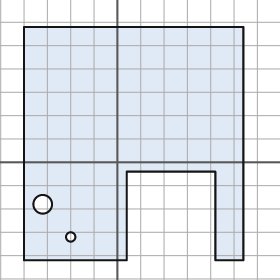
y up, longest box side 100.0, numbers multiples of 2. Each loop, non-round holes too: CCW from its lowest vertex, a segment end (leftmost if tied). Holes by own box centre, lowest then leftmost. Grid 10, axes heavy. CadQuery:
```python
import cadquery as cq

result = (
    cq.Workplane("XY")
    .moveTo(-40.0, -42.0)
    .lineTo(4.0, -42.0)
    .lineTo(4.0, -4.0)
    .lineTo(42.0, -4.0)
    .lineTo(42.0, -42.0)
    .lineTo(54.0, -42.0)
    .lineTo(54.0, 58.0)
    .lineTo(-40.0, 58.0)
    .close()
    .moveTo(-20.0, -32.0)
    .circle(2.0)
    .moveTo(-32.0, -18.0)
    .circle(4.0)
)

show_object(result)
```